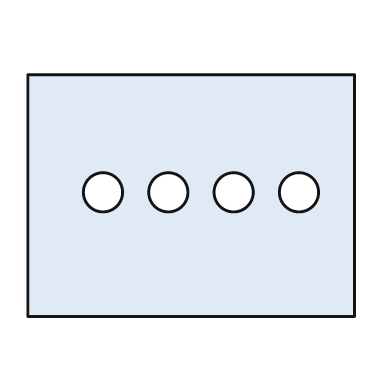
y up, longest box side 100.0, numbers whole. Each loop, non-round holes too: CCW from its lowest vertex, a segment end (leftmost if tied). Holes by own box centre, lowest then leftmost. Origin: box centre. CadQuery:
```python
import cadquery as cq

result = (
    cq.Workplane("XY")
    .moveTo(-50.0, -37.0)
    .lineTo(50.0, -37.0)
    .lineTo(50.0, 37.0)
    .lineTo(-50.0, 37.0)
    .close()
    .moveTo(-27.0, 1.0)
    .circle(6.0)
    .moveTo(-7.0, 1.0)
    .circle(6.0)
    .moveTo(13.0, 1.0)
    .circle(6.0)
    .moveTo(33.0, 1.0)
    .circle(6.0)
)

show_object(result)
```